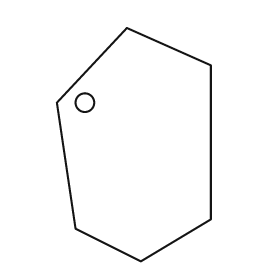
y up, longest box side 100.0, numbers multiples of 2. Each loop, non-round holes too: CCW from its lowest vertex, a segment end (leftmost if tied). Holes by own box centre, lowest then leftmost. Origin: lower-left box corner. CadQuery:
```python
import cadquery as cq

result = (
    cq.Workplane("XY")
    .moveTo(36.0, 0.0)
    .lineTo(66.0, 18.0)
    .lineTo(66.0, 84.0)
    .lineTo(30.0, 100.0)
    .lineTo(0.0, 68.0)
    .lineTo(8.0, 14.0)
    .close()
    .moveTo(12.0, 68.0)
    .circle(4.0)
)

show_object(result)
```